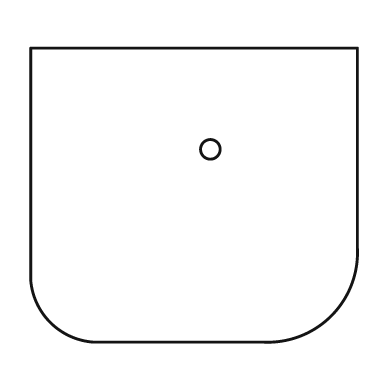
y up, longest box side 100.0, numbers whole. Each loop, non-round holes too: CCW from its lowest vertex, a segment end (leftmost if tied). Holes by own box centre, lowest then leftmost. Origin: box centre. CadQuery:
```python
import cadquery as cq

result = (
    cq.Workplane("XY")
    .moveTo(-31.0, -45.0)
    .lineTo(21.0, -45.0)
    .threePointArc((42.0, -37.0), (50.0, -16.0))
    .lineTo(50.0, 45.0)
    .lineTo(-50.0, 45.0)
    .lineTo(-50.0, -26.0)
    .threePointArc((-44.0, -39.0), (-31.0, -45.0))
    .close()
    .moveTo(5.0, 14.0)
    .circle(3.0)
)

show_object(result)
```